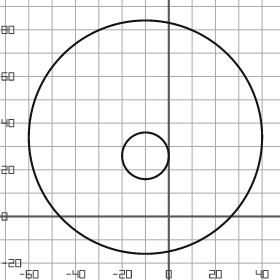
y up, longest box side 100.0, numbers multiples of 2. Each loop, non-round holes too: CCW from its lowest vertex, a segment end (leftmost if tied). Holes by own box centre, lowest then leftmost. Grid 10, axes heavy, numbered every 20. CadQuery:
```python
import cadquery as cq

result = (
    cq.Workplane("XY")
    .moveTo(-10.0, 34.0)
    .circle(50.0)
    .moveTo(-10.0, 26.0)
    .circle(10.0)
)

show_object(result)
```